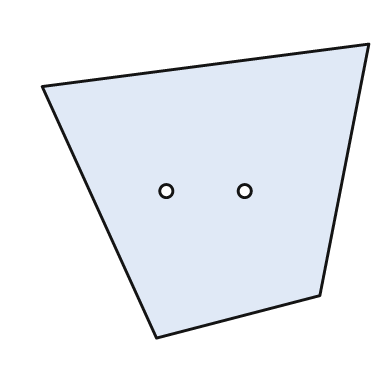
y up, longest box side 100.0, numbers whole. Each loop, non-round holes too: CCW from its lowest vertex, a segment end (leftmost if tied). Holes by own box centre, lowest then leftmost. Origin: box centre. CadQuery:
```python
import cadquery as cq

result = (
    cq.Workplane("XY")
    .moveTo(-15.0, -45.0)
    .lineTo(35.0, -32.0)
    .lineTo(50.0, 45.0)
    .lineTo(-50.0, 32.0)
    .close()
    .moveTo(-12.0, 0.0)
    .circle(2.0)
    .moveTo(12.0, 0.0)
    .circle(2.0)
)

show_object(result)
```